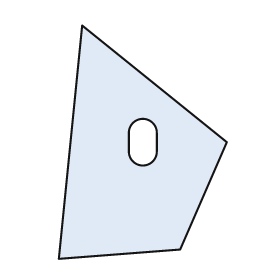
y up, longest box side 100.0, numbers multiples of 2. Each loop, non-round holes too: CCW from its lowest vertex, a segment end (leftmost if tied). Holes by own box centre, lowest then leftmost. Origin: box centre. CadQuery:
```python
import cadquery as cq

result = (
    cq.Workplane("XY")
    .moveTo(-36.0, -50.0)
    .lineTo(16.0, -46.0)
    .lineTo(36.0, 0.0)
    .lineTo(-26.0, 50.0)
    .close()
    .moveTo(-6.0, -4.0)
    .threePointArc((0.0, -10.0), (6.0, -4.0))
    .lineTo(6.0, 4.0)
    .threePointArc((0.0, 10.0), (-6.0, 4.0))
    .close()
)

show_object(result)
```